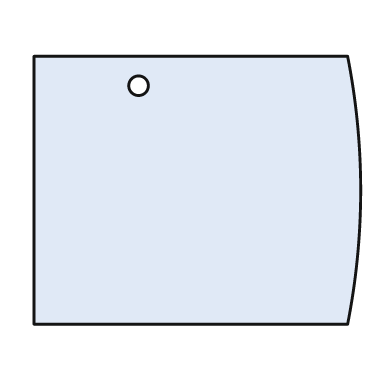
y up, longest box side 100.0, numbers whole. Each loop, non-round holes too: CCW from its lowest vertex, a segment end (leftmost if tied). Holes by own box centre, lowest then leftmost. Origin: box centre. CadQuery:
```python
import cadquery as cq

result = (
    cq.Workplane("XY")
    .moveTo(-50.0, -41.0)
    .lineTo(46.0, -41.0)
    .threePointArc((50.0, 0.0), (46.0, 41.0))
    .lineTo(-50.0, 41.0)
    .close()
    .moveTo(-18.0, 32.0)
    .circle(3.0)
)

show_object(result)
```